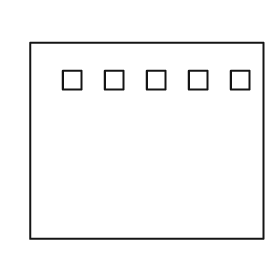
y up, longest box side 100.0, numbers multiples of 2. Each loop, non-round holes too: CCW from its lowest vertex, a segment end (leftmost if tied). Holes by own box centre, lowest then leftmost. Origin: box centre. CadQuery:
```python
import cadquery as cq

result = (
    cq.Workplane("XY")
    .moveTo(-50.0, -42.0)
    .lineTo(50.0, -42.0)
    .lineTo(50.0, 42.0)
    .lineTo(-50.0, 42.0)
    .close()
    .moveTo(-36.0, 22.0)
    .lineTo(-28.0, 22.0)
    .lineTo(-28.0, 30.0)
    .lineTo(-36.0, 30.0)
    .close()
    .moveTo(-18.0, 22.0)
    .lineTo(-10.0, 22.0)
    .lineTo(-10.0, 30.0)
    .lineTo(-18.0, 30.0)
    .close()
    .moveTo(0.0, 22.0)
    .lineTo(8.0, 22.0)
    .lineTo(8.0, 30.0)
    .lineTo(0.0, 30.0)
    .close()
    .moveTo(18.0, 22.0)
    .lineTo(26.0, 22.0)
    .lineTo(26.0, 30.0)
    .lineTo(18.0, 30.0)
    .close()
    .moveTo(36.0, 22.0)
    .lineTo(44.0, 22.0)
    .lineTo(44.0, 30.0)
    .lineTo(36.0, 30.0)
    .close()
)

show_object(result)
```